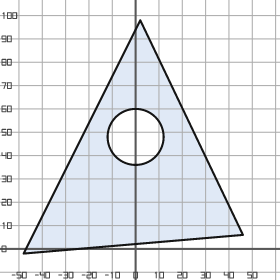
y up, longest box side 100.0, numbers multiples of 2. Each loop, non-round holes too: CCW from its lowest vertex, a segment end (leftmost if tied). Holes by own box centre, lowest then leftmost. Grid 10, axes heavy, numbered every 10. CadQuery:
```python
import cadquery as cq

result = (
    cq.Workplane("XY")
    .moveTo(-48.0, -2.0)
    .lineTo(46.0, 6.0)
    .lineTo(2.0, 98.0)
    .close()
    .moveTo(0.0, 48.0)
    .circle(12.0)
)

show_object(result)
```